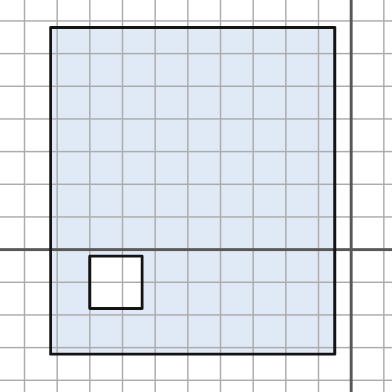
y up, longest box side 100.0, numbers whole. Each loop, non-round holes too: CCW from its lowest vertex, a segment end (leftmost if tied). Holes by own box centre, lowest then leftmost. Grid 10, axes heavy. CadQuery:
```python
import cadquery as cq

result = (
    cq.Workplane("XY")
    .moveTo(-92.0, -32.0)
    .lineTo(-5.0, -32.0)
    .lineTo(-5.0, 68.0)
    .lineTo(-92.0, 68.0)
    .close()
    .moveTo(-80.0, -18.0)
    .lineTo(-64.0, -18.0)
    .lineTo(-64.0, -2.0)
    .lineTo(-80.0, -2.0)
    .close()
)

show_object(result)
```